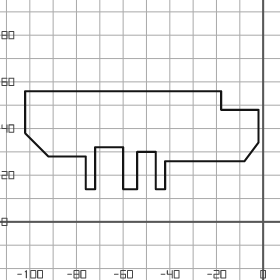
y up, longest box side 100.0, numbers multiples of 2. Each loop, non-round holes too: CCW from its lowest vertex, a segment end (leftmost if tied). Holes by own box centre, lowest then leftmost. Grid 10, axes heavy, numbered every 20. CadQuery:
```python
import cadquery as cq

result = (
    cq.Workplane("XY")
    .moveTo(-76.0, 14.0)
    .lineTo(-72.0, 14.0)
    .lineTo(-72.0, 32.0)
    .lineTo(-60.0, 32.0)
    .lineTo(-60.0, 14.0)
    .lineTo(-54.0, 14.0)
    .lineTo(-54.0, 30.0)
    .lineTo(-46.0, 30.0)
    .lineTo(-46.0, 14.0)
    .lineTo(-42.0, 14.0)
    .lineTo(-42.0, 26.0)
    .lineTo(-8.0, 26.0)
    .lineTo(-2.0, 34.0)
    .lineTo(-2.0, 48.0)
    .lineTo(-18.0, 48.0)
    .lineTo(-18.0, 56.0)
    .lineTo(-102.0, 56.0)
    .lineTo(-102.0, 38.0)
    .lineTo(-92.0, 28.0)
    .lineTo(-76.0, 28.0)
    .close()
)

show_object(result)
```